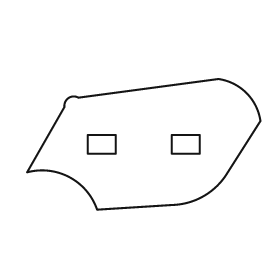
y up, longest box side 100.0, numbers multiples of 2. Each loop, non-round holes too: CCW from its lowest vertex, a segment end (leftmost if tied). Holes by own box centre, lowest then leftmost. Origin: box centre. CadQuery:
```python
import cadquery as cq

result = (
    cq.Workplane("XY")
    .moveTo(-20.0, -28.0)
    .lineTo(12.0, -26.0)
    .threePointArc((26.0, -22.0), (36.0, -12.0))
    .lineTo(50.0, 10.0)
    .threePointArc((44.0, 22.0), (32.0, 28.0))
    .lineTo(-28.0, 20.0)
    .threePointArc((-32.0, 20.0), (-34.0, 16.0))
    .lineTo(-50.0, -12.0)
    .threePointArc((-32.0, -14.0), (-20.0, -28.0))
    .close()
    .moveTo(-24.0, -4.0)
    .lineTo(-12.0, -4.0)
    .lineTo(-12.0, 4.0)
    .lineTo(-24.0, 4.0)
    .close()
    .moveTo(12.0, -4.0)
    .lineTo(24.0, -4.0)
    .lineTo(24.0, 4.0)
    .lineTo(12.0, 4.0)
    .close()
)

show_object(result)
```